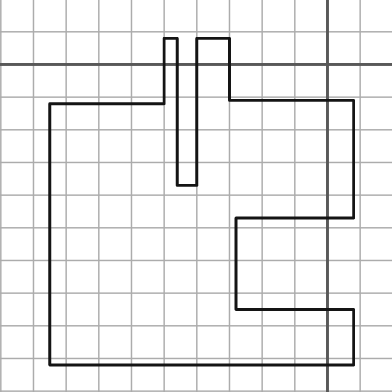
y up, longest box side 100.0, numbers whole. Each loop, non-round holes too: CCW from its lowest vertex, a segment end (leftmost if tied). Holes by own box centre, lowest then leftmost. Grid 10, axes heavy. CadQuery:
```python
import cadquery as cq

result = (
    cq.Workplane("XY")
    .moveTo(-85.0, -92.0)
    .lineTo(8.0, -92.0)
    .lineTo(8.0, -75.0)
    .lineTo(-28.0, -75.0)
    .lineTo(-28.0, -47.0)
    .lineTo(8.0, -47.0)
    .lineTo(8.0, -11.0)
    .lineTo(-30.0, -11.0)
    .lineTo(-30.0, 8.0)
    .lineTo(-40.0, 8.0)
    .lineTo(-40.0, -37.0)
    .lineTo(-46.0, -37.0)
    .lineTo(-46.0, 8.0)
    .lineTo(-50.0, 8.0)
    .lineTo(-50.0, -12.0)
    .lineTo(-85.0, -12.0)
    .close()
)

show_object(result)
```